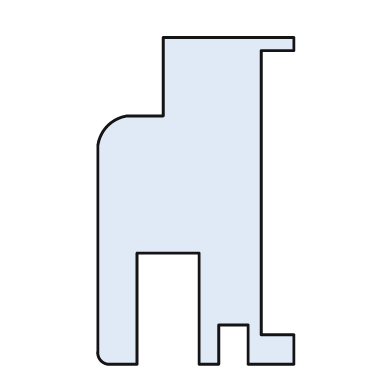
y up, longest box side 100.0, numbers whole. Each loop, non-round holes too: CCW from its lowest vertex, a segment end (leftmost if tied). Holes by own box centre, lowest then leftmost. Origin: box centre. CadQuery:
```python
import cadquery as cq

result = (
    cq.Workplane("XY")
    .moveTo(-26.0, -50.0)
    .lineTo(-18.0, -50.0)
    .lineTo(-18.0, -16.0)
    .lineTo(1.0, -16.0)
    .lineTo(1.0, -50.0)
    .lineTo(7.0, -50.0)
    .lineTo(7.0, -38.0)
    .lineTo(16.0, -38.0)
    .lineTo(16.0, -50.0)
    .lineTo(30.0, -50.0)
    .lineTo(30.0, -41.0)
    .lineTo(20.0, -41.0)
    .lineTo(20.0, 46.0)
    .lineTo(30.0, 46.0)
    .lineTo(30.0, 50.0)
    .lineTo(-10.0, 50.0)
    .lineTo(-10.0, 26.0)
    .lineTo(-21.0, 26.0)
    .threePointArc((-27.0, 23.0), (-30.0, 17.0))
    .lineTo(-30.0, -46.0)
    .threePointArc((-29.0, -49.0), (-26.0, -50.0))
    .close()
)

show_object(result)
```